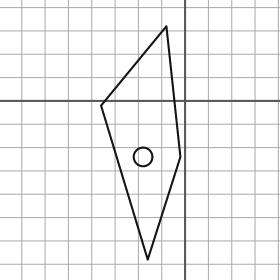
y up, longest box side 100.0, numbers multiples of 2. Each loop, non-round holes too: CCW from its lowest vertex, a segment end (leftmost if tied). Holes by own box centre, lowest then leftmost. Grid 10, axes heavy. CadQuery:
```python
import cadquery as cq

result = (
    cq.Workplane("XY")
    .moveTo(-16.0, -68.0)
    .lineTo(-2.0, -24.0)
    .lineTo(-8.0, 32.0)
    .lineTo(-36.0, -2.0)
    .close()
    .moveTo(-18.0, -24.0)
    .circle(4.0)
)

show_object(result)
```